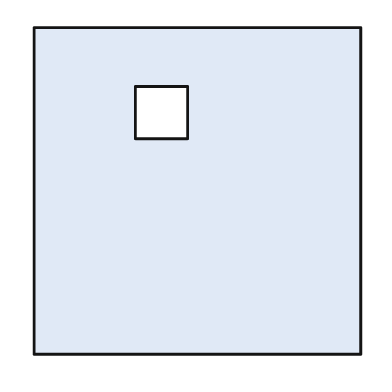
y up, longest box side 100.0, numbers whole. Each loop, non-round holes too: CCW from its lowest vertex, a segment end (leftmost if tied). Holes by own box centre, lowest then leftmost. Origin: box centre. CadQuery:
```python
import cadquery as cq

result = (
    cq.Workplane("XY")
    .moveTo(-50.0, -50.0)
    .lineTo(50.0, -50.0)
    .lineTo(50.0, 50.0)
    .lineTo(-50.0, 50.0)
    .close()
    .moveTo(-19.0, 16.0)
    .lineTo(-3.0, 16.0)
    .lineTo(-3.0, 32.0)
    .lineTo(-19.0, 32.0)
    .close()
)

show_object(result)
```